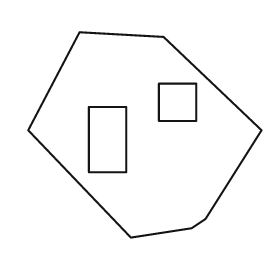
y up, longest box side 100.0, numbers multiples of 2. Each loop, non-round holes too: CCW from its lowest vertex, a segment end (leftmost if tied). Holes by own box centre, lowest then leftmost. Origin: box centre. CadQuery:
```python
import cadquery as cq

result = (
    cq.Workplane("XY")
    .moveTo(-6.0, -44.0)
    .lineTo(20.0, -40.0)
    .lineTo(26.0, -36.0)
    .lineTo(50.0, 2.0)
    .lineTo(8.0, 42.0)
    .lineTo(-28.0, 44.0)
    .lineTo(-50.0, 2.0)
    .close()
    .moveTo(-24.0, -16.0)
    .lineTo(-8.0, -16.0)
    .lineTo(-8.0, 12.0)
    .lineTo(-24.0, 12.0)
    .close()
    .moveTo(6.0, 6.0)
    .lineTo(22.0, 6.0)
    .lineTo(22.0, 22.0)
    .lineTo(6.0, 22.0)
    .close()
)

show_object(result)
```